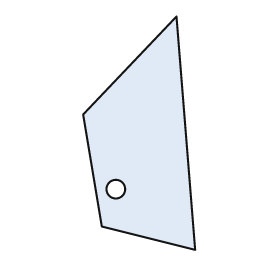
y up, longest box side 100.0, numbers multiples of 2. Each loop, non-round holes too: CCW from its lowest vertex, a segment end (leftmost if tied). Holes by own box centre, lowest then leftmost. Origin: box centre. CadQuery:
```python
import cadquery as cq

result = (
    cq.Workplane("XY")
    .moveTo(24.0, -50.0)
    .lineTo(16.0, 50.0)
    .lineTo(-24.0, 8.0)
    .lineTo(-16.0, -40.0)
    .close()
    .moveTo(-10.0, -24.0)
    .circle(4.0)
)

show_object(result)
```